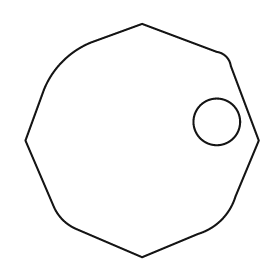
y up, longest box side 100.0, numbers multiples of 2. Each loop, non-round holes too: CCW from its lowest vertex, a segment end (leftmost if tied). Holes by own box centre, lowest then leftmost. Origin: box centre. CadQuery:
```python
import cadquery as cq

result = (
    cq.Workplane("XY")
    .moveTo(0.0, -50.0)
    .lineTo(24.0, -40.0)
    .threePointArc((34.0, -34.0), (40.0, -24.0))
    .lineTo(50.0, 0.0)
    .lineTo(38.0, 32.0)
    .threePointArc((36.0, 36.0), (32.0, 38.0))
    .lineTo(0.0, 50.0)
    .lineTo(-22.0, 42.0)
    .threePointArc((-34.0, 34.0), (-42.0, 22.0))
    .lineTo(-50.0, 0.0)
    .lineTo(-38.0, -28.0)
    .threePointArc((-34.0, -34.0), (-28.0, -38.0))
    .close()
    .moveTo(32.0, 8.0)
    .circle(10.0)
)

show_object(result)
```